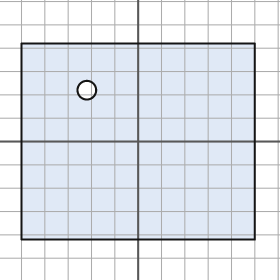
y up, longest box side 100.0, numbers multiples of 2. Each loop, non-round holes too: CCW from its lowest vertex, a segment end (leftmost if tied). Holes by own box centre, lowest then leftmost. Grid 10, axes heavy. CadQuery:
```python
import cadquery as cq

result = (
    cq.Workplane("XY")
    .moveTo(-50.0, -42.0)
    .lineTo(50.0, -42.0)
    .lineTo(50.0, 42.0)
    .lineTo(-50.0, 42.0)
    .close()
    .moveTo(-22.0, 22.0)
    .circle(4.0)
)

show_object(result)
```